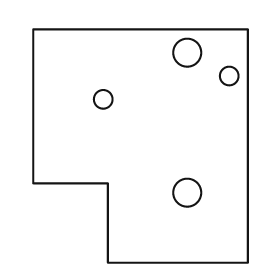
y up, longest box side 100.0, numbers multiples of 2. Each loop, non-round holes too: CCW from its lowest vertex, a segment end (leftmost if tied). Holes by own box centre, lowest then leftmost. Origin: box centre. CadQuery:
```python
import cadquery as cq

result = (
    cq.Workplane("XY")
    .moveTo(-14.0, -50.0)
    .lineTo(46.0, -50.0)
    .lineTo(46.0, 50.0)
    .lineTo(-46.0, 50.0)
    .lineTo(-46.0, -16.0)
    .lineTo(-14.0, -16.0)
    .close()
    .moveTo(20.0, -20.0)
    .circle(6.0)
    .moveTo(-16.0, 20.0)
    .circle(4.0)
    .moveTo(38.0, 30.0)
    .circle(4.0)
    .moveTo(20.0, 40.0)
    .circle(6.0)
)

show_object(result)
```